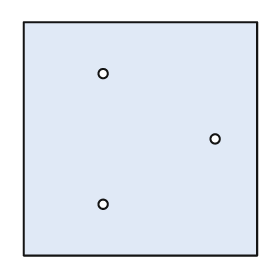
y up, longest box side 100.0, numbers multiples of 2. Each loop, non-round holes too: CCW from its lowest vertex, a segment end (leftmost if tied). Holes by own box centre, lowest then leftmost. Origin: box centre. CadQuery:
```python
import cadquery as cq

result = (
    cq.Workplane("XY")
    .moveTo(-50.0, -50.0)
    .lineTo(50.0, -50.0)
    .lineTo(50.0, 50.0)
    .lineTo(-50.0, 50.0)
    .close()
    .moveTo(-16.0, -28.0)
    .circle(2.0)
    .moveTo(32.0, 0.0)
    .circle(2.0)
    .moveTo(-16.0, 28.0)
    .circle(2.0)
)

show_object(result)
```